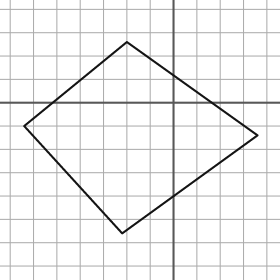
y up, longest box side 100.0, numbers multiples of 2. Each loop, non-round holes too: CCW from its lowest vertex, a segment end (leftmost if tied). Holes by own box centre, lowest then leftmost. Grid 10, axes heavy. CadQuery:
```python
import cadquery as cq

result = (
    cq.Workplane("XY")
    .moveTo(-22.0, -56.0)
    .lineTo(36.0, -14.0)
    .lineTo(-20.0, 26.0)
    .lineTo(-64.0, -10.0)
    .close()
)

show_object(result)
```